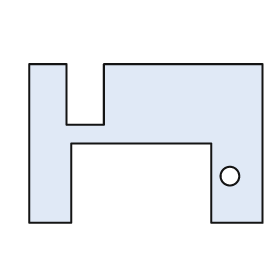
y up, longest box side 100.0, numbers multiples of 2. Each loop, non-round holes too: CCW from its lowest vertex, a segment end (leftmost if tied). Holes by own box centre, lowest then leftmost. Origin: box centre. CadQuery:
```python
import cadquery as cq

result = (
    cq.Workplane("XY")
    .moveTo(-50.0, -34.0)
    .lineTo(-32.0, -34.0)
    .lineTo(-32.0, 0.0)
    .lineTo(28.0, 0.0)
    .lineTo(28.0, -34.0)
    .lineTo(50.0, -34.0)
    .lineTo(50.0, 34.0)
    .lineTo(-18.0, 34.0)
    .lineTo(-18.0, 8.0)
    .lineTo(-34.0, 8.0)
    .lineTo(-34.0, 34.0)
    .lineTo(-50.0, 34.0)
    .close()
    .moveTo(36.0, -14.0)
    .circle(4.0)
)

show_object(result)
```